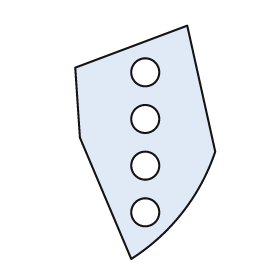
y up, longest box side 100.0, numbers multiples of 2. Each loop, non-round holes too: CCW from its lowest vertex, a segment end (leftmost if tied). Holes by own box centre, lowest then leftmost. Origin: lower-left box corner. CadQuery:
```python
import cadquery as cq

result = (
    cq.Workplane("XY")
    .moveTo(24.0, 0.0)
    .threePointArc((46.0, 20.0), (60.0, 46.0))
    .lineTo(48.0, 100.0)
    .lineTo(0.0, 82.0)
    .lineTo(2.0, 52.0)
    .close()
    .moveTo(30.0, 20.0)
    .circle(6.0)
    .moveTo(30.0, 40.0)
    .circle(6.0)
    .moveTo(30.0, 60.0)
    .circle(6.0)
    .moveTo(30.0, 80.0)
    .circle(6.0)
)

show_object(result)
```